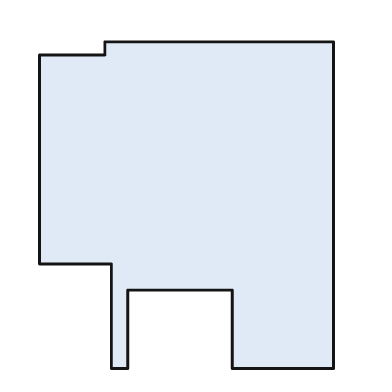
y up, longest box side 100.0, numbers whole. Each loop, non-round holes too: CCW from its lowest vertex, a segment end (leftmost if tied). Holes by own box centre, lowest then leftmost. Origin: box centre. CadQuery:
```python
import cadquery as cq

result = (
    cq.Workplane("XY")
    .moveTo(-23.0, -50.0)
    .lineTo(-18.0, -50.0)
    .lineTo(-18.0, -26.0)
    .lineTo(14.0, -26.0)
    .lineTo(14.0, -50.0)
    .lineTo(45.0, -50.0)
    .lineTo(45.0, 50.0)
    .lineTo(-25.0, 50.0)
    .lineTo(-25.0, 46.0)
    .lineTo(-45.0, 46.0)
    .lineTo(-45.0, -18.0)
    .lineTo(-23.0, -18.0)
    .close()
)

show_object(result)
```